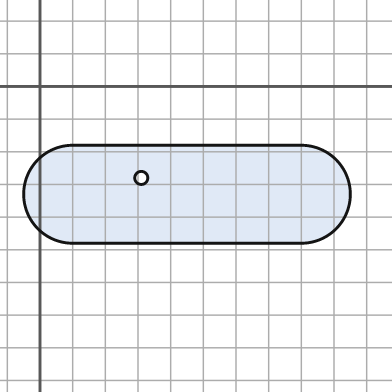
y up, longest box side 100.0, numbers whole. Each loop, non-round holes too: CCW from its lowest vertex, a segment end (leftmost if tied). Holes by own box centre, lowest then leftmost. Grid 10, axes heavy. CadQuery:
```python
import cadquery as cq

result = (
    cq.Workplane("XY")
    .moveTo(10.0, -48.0)
    .lineTo(80.0, -48.0)
    .threePointArc((95.0, -33.0), (80.0, -18.0))
    .lineTo(10.0, -18.0)
    .threePointArc((-5.0, -33.0), (10.0, -48.0))
    .close()
    .moveTo(31.0, -28.0)
    .circle(2.0)
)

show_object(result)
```